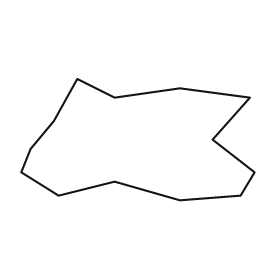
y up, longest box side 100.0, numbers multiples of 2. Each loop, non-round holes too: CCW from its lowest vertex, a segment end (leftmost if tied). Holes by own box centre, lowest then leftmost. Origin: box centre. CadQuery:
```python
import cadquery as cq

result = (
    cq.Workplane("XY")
    .moveTo(18.0, -26.0)
    .lineTo(44.0, -24.0)
    .lineTo(50.0, -14.0)
    .lineTo(32.0, 0.0)
    .lineTo(48.0, 18.0)
    .lineTo(18.0, 22.0)
    .lineTo(-10.0, 18.0)
    .lineTo(-26.0, 26.0)
    .lineTo(-36.0, 8.0)
    .lineTo(-46.0, -4.0)
    .lineTo(-50.0, -14.0)
    .lineTo(-34.0, -24.0)
    .lineTo(-10.0, -18.0)
    .close()
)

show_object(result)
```